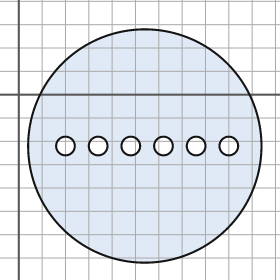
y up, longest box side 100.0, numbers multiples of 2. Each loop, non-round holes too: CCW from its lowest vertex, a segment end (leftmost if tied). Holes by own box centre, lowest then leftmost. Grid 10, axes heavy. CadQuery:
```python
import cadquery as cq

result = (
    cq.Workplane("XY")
    .moveTo(54.0, -22.0)
    .circle(50.0)
    .moveTo(20.0, -22.0)
    .circle(4.0)
    .moveTo(34.0, -22.0)
    .circle(4.0)
    .moveTo(48.0, -22.0)
    .circle(4.0)
    .moveTo(62.0, -22.0)
    .circle(4.0)
    .moveTo(76.0, -22.0)
    .circle(4.0)
    .moveTo(90.0, -22.0)
    .circle(4.0)
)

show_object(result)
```